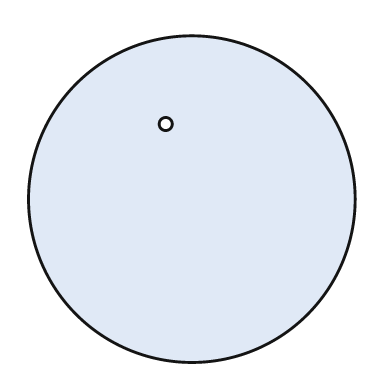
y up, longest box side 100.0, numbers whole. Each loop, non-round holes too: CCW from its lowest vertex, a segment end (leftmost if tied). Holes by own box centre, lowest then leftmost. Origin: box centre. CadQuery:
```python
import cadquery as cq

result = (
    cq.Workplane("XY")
    .moveTo(0.0, 0.0)
    .circle(50.0)
    .moveTo(-8.0, 23.0)
    .circle(2.0)
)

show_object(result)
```